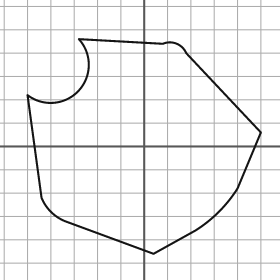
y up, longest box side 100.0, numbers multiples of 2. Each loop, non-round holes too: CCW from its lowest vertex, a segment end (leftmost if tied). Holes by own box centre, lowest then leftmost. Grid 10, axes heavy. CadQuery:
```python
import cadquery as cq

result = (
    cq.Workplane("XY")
    .moveTo(4.0, -46.0)
    .lineTo(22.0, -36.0)
    .threePointArc((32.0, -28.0), (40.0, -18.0))
    .lineTo(50.0, 6.0)
    .lineTo(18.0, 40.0)
    .threePointArc((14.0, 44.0), (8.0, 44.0))
    .lineTo(-28.0, 46.0)
    .threePointArc((-28.0, 24.0), (-50.0, 22.0))
    .lineTo(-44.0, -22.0)
    .threePointArc((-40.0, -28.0), (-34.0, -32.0))
    .close()
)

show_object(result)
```